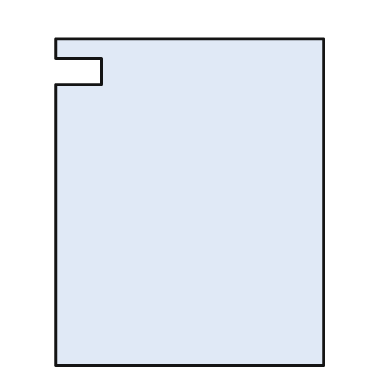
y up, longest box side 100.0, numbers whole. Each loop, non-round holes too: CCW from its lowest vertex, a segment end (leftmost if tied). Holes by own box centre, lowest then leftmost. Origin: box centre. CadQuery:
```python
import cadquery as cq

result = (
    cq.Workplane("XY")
    .moveTo(-41.0, -50.0)
    .lineTo(41.0, -50.0)
    .lineTo(41.0, 50.0)
    .lineTo(-41.0, 50.0)
    .lineTo(-41.0, 44.0)
    .lineTo(-27.0, 44.0)
    .lineTo(-27.0, 36.0)
    .lineTo(-41.0, 36.0)
    .close()
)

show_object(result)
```